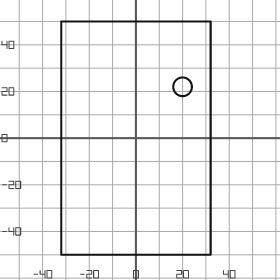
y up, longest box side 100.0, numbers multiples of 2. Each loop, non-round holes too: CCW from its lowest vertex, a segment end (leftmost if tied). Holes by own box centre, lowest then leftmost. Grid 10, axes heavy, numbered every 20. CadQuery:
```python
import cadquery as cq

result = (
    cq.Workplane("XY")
    .moveTo(-32.0, -50.0)
    .lineTo(32.0, -50.0)
    .lineTo(32.0, 50.0)
    .lineTo(-32.0, 50.0)
    .close()
    .moveTo(20.0, 22.0)
    .circle(4.0)
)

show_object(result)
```